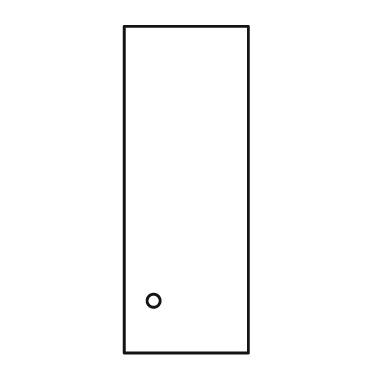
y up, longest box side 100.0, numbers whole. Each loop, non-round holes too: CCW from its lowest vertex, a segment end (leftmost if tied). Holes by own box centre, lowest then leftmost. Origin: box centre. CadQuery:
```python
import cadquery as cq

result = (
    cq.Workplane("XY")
    .moveTo(-19.0, -50.0)
    .lineTo(19.0, -50.0)
    .lineTo(19.0, 50.0)
    .lineTo(-19.0, 50.0)
    .close()
    .moveTo(-10.0, -34.0)
    .circle(2.0)
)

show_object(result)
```